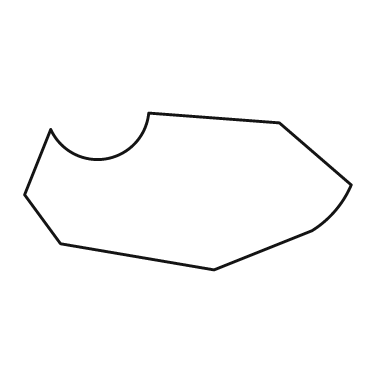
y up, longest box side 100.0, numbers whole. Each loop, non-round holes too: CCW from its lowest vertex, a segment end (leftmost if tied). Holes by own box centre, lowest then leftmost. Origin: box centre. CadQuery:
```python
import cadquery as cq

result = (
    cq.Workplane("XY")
    .moveTo(8.0, -24.0)
    .lineTo(38.0, -12.0)
    .threePointArc((45.0, -6.0), (50.0, 2.0))
    .lineTo(28.0, 21.0)
    .lineTo(-12.0, 24.0)
    .threePointArc((-25.0, 10.0), (-42.0, 19.0))
    .lineTo(-50.0, -1.0)
    .lineTo(-39.0, -16.0)
    .close()
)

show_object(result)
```